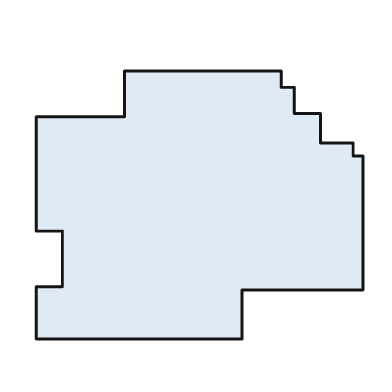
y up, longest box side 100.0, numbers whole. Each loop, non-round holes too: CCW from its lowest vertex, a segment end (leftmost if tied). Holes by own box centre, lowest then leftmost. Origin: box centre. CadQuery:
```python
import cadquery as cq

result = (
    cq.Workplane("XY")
    .moveTo(-50.0, -41.0)
    .lineTo(13.0, -41.0)
    .lineTo(13.0, -26.0)
    .lineTo(50.0, -26.0)
    .lineTo(50.0, 15.0)
    .lineTo(47.0, 15.0)
    .lineTo(47.0, 19.0)
    .lineTo(37.0, 19.0)
    .lineTo(37.0, 28.0)
    .lineTo(29.0, 28.0)
    .lineTo(29.0, 36.0)
    .lineTo(25.0, 36.0)
    .lineTo(25.0, 41.0)
    .lineTo(-23.0, 41.0)
    .lineTo(-23.0, 27.0)
    .lineTo(-50.0, 27.0)
    .lineTo(-50.0, -8.0)
    .lineTo(-42.0, -8.0)
    .lineTo(-42.0, -25.0)
    .lineTo(-50.0, -25.0)
    .close()
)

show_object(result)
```